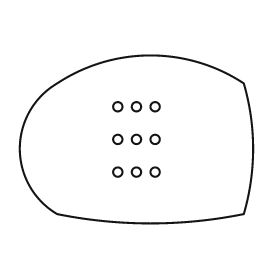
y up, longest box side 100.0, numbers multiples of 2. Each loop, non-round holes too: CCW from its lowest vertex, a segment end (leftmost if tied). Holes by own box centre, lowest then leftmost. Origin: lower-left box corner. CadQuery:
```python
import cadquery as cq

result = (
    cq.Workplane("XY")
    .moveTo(16.0, 4.0)
    .threePointArc((56.0, 0.0), (96.0, 4.0))
    .threePointArc((100.0, 32.0), (96.0, 60.0))
    .threePointArc((56.0, 72.0), (16.0, 60.0))
    .threePointArc((0.0, 32.0), (16.0, 4.0))
    .close()
    .moveTo(42.0, 22.0)
    .circle(2.0)
    .moveTo(50.0, 22.0)
    .circle(2.0)
    .moveTo(58.0, 22.0)
    .circle(2.0)
    .moveTo(42.0, 36.0)
    .circle(2.0)
    .moveTo(50.0, 36.0)
    .circle(2.0)
    .moveTo(58.0, 36.0)
    .circle(2.0)
    .moveTo(42.0, 50.0)
    .circle(2.0)
    .moveTo(50.0, 50.0)
    .circle(2.0)
    .moveTo(58.0, 50.0)
    .circle(2.0)
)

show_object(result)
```